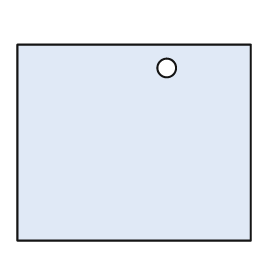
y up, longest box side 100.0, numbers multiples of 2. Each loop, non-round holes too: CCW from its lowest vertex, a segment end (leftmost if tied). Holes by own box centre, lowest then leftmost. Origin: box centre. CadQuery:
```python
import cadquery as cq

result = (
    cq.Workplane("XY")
    .moveTo(-50.0, -42.0)
    .lineTo(50.0, -42.0)
    .lineTo(50.0, 42.0)
    .lineTo(-50.0, 42.0)
    .close()
    .moveTo(14.0, 32.0)
    .circle(4.0)
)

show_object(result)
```